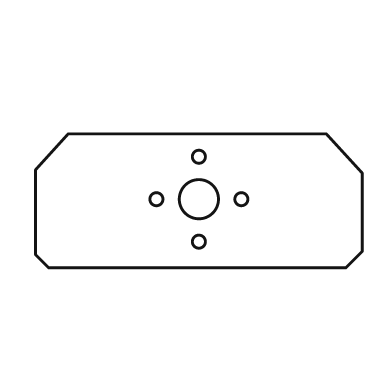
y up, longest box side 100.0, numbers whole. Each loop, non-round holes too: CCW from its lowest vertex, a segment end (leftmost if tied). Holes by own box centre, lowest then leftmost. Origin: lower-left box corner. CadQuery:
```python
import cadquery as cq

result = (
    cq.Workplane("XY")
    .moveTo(4.0, 0.0)
    .lineTo(95.0, 0.0)
    .lineTo(100.0, 5.0)
    .lineTo(100.0, 29.0)
    .lineTo(89.0, 41.0)
    .lineTo(10.0, 41.0)
    .lineTo(0.0, 30.0)
    .lineTo(0.0, 4.0)
    .close()
    .moveTo(50.0, 8.0)
    .circle(2.0)
    .moveTo(37.0, 21.0)
    .circle(2.0)
    .moveTo(50.0, 21.0)
    .circle(6.0)
    .moveTo(63.0, 21.0)
    .circle(2.0)
    .moveTo(50.0, 34.0)
    .circle(2.0)
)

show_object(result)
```